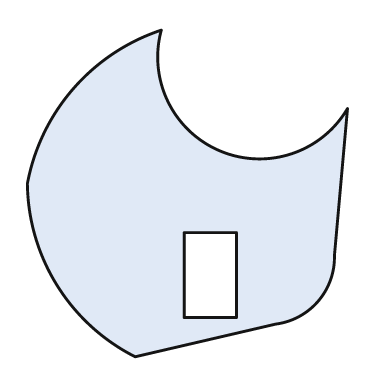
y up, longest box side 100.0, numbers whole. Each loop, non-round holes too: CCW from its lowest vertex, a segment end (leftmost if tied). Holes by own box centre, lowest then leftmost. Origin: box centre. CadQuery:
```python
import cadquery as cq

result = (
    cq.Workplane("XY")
    .moveTo(-16.0, -50.0)
    .lineTo(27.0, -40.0)
    .threePointArc((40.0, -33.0), (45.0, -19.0))
    .lineTo(49.0, 26.0)
    .threePointArc((10.0, 13.0), (-8.0, 50.0))
    .threePointArc((-35.0, 32.0), (-49.0, 3.0))
    .threePointArc((-40.0, -28.0), (-16.0, -50.0))
    .close()
    .moveTo(-1.0, -38.0)
    .lineTo(15.0, -38.0)
    .lineTo(15.0, -12.0)
    .lineTo(-1.0, -12.0)
    .close()
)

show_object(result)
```